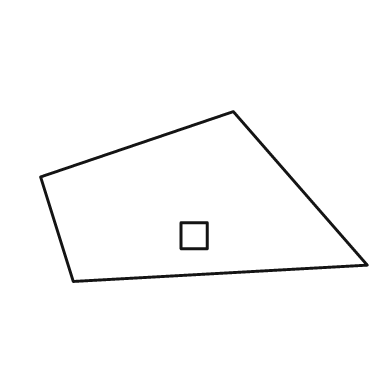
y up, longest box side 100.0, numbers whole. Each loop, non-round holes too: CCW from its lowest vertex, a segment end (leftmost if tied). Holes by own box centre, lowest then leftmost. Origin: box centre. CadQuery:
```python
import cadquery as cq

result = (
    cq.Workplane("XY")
    .moveTo(-40.0, -26.0)
    .lineTo(50.0, -21.0)
    .lineTo(9.0, 26.0)
    .lineTo(-50.0, 6.0)
    .close()
    .moveTo(-7.0, -16.0)
    .lineTo(1.0, -16.0)
    .lineTo(1.0, -8.0)
    .lineTo(-7.0, -8.0)
    .close()
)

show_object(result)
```